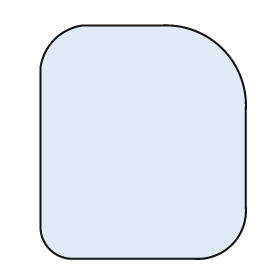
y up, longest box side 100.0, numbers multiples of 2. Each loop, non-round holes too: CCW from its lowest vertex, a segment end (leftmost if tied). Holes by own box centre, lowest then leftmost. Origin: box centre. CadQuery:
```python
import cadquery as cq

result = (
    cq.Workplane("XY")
    .moveTo(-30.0, -50.0)
    .lineTo(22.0, -50.0)
    .threePointArc((38.0, -44.0), (44.0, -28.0))
    .lineTo(44.0, 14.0)
    .threePointArc((34.0, 40.0), (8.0, 50.0))
    .lineTo(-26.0, 50.0)
    .threePointArc((-38.0, 44.0), (-44.0, 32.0))
    .lineTo(-44.0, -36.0)
    .threePointArc((-40.0, -46.0), (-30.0, -50.0))
    .close()
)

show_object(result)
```